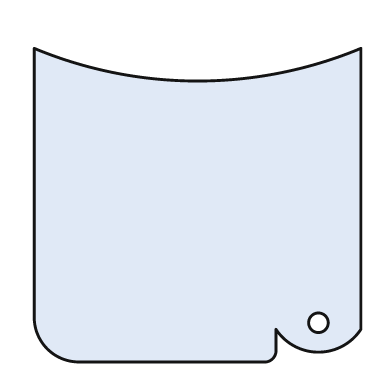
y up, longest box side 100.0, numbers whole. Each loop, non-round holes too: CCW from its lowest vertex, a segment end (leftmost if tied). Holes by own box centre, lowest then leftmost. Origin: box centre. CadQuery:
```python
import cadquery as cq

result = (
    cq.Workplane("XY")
    .moveTo(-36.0, -48.0)
    .lineTo(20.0, -48.0)
    .threePointArc((23.0, -47.0), (24.0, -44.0))
    .lineTo(24.0, -38.0)
    .threePointArc((37.0, -45.0), (50.0, -38.0))
    .lineTo(50.0, 48.0)
    .threePointArc((0.0, 38.0), (-50.0, 48.0))
    .lineTo(-50.0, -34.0)
    .threePointArc((-46.0, -44.0), (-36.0, -48.0))
    .close()
    .moveTo(37.0, -36.0)
    .circle(3.0)
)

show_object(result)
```